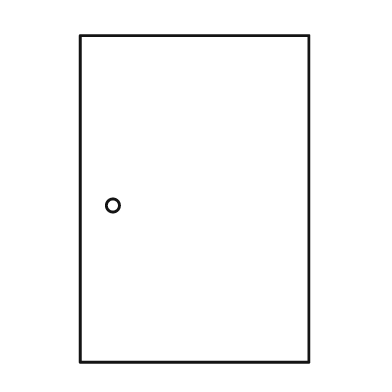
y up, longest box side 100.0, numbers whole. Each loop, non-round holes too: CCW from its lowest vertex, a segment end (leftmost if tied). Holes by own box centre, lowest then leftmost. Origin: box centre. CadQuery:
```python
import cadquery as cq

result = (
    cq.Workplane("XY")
    .moveTo(-35.0, -50.0)
    .lineTo(35.0, -50.0)
    .lineTo(35.0, 50.0)
    .lineTo(-35.0, 50.0)
    .close()
    .moveTo(-25.0, -2.0)
    .circle(2.0)
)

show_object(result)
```